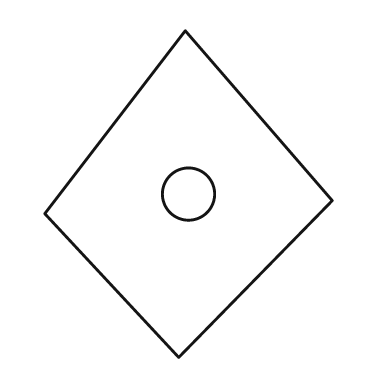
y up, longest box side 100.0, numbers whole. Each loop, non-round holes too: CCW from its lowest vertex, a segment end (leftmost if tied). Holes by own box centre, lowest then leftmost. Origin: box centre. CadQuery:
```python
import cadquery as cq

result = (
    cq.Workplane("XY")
    .moveTo(-3.0, -50.0)
    .lineTo(44.0, -2.0)
    .lineTo(-1.0, 50.0)
    .lineTo(-44.0, -6.0)
    .close()
    .moveTo(0.0, 0.0)
    .circle(8.0)
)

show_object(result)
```